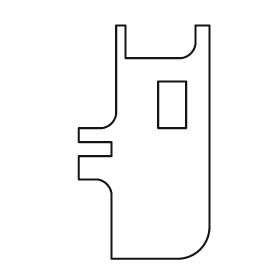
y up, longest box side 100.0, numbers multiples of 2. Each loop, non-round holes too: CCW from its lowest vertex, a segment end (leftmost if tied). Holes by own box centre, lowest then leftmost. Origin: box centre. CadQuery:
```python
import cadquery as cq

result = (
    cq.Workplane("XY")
    .moveTo(-14.0, -50.0)
    .lineTo(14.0, -50.0)
    .threePointArc((24.0, -46.0), (28.0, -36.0))
    .lineTo(28.0, 50.0)
    .lineTo(22.0, 50.0)
    .lineTo(22.0, 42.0)
    .threePointArc((20.0, 38.0), (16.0, 36.0))
    .lineTo(-8.0, 36.0)
    .lineTo(-8.0, 50.0)
    .lineTo(-12.0, 50.0)
    .lineTo(-12.0, 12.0)
    .threePointArc((-14.0, 8.0), (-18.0, 6.0))
    .lineTo(-28.0, 6.0)
    .lineTo(-28.0, 0.0)
    .lineTo(-14.0, 0.0)
    .lineTo(-14.0, -6.0)
    .lineTo(-28.0, -6.0)
    .lineTo(-28.0, -16.0)
    .lineTo(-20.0, -16.0)
    .threePointArc((-16.0, -18.0), (-14.0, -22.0))
    .close()
    .moveTo(6.0, 6.0)
    .lineTo(18.0, 6.0)
    .lineTo(18.0, 26.0)
    .lineTo(6.0, 26.0)
    .close()
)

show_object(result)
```